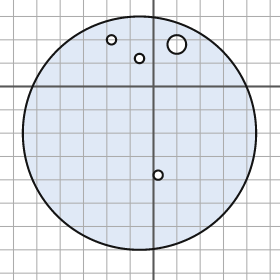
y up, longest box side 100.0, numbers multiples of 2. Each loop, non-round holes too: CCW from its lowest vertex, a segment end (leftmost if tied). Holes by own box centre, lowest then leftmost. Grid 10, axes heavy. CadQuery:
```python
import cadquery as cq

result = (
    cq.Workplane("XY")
    .moveTo(-6.0, -20.0)
    .circle(50.0)
    .moveTo(2.0, -38.0)
    .circle(2.0)
    .moveTo(-6.0, 12.0)
    .circle(2.0)
    .moveTo(10.0, 18.0)
    .circle(4.0)
    .moveTo(-18.0, 20.0)
    .circle(2.0)
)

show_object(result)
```